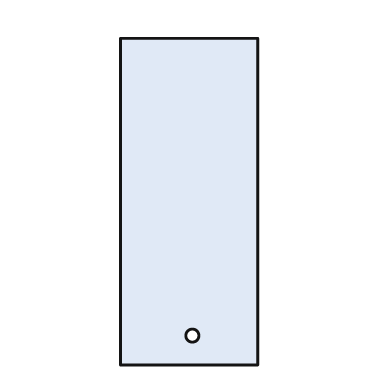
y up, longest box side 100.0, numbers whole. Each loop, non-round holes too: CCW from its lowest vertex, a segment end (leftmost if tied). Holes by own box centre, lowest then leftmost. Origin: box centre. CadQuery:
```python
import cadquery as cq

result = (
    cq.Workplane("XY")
    .moveTo(-21.0, -50.0)
    .lineTo(21.0, -50.0)
    .lineTo(21.0, 50.0)
    .lineTo(-21.0, 50.0)
    .close()
    .moveTo(1.0, -41.0)
    .circle(2.0)
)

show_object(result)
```